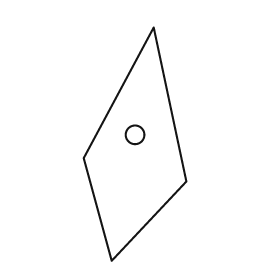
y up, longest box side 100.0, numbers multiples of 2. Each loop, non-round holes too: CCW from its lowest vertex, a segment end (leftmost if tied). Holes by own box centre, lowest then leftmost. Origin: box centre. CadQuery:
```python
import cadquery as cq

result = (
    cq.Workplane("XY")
    .moveTo(-10.0, -50.0)
    .lineTo(22.0, -16.0)
    .lineTo(8.0, 50.0)
    .lineTo(-22.0, -6.0)
    .close()
    .moveTo(0.0, 4.0)
    .circle(4.0)
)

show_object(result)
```